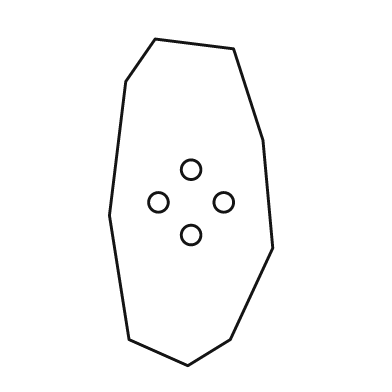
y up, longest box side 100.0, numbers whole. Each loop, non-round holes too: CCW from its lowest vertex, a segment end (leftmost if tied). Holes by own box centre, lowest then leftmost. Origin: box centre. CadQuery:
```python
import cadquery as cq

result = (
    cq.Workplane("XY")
    .moveTo(-1.0, -50.0)
    .lineTo(12.0, -42.0)
    .lineTo(25.0, -14.0)
    .lineTo(22.0, 19.0)
    .lineTo(13.0, 47.0)
    .lineTo(-11.0, 50.0)
    .lineTo(-20.0, 37.0)
    .lineTo(-25.0, -4.0)
    .lineTo(-19.0, -42.0)
    .close()
    .moveTo(0.0, -10.0)
    .circle(3.0)
    .moveTo(-10.0, 0.0)
    .circle(3.0)
    .moveTo(10.0, 0.0)
    .circle(3.0)
    .moveTo(0.0, 10.0)
    .circle(3.0)
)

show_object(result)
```